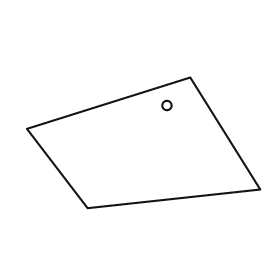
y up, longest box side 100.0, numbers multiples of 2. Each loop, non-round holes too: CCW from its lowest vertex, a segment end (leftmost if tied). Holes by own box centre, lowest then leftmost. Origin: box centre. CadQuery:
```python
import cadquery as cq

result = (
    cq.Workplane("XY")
    .moveTo(-24.0, -28.0)
    .lineTo(50.0, -20.0)
    .lineTo(20.0, 28.0)
    .lineTo(-50.0, 6.0)
    .close()
    .moveTo(10.0, 16.0)
    .circle(2.0)
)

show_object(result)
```